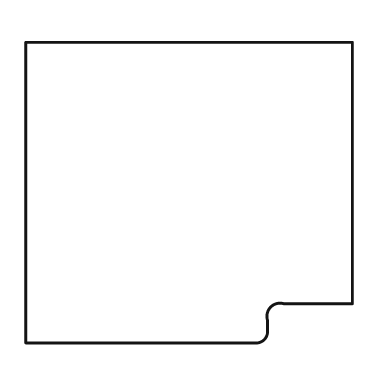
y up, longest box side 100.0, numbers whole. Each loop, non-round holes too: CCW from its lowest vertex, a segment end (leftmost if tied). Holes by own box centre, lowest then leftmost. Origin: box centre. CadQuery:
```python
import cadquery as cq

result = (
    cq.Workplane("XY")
    .moveTo(-50.0, -46.0)
    .lineTo(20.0, -46.0)
    .threePointArc((23.0, -45.0), (24.0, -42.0))
    .lineTo(24.0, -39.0)
    .threePointArc((25.0, -35.0), (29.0, -34.0))
    .lineTo(50.0, -34.0)
    .lineTo(50.0, 46.0)
    .lineTo(-50.0, 46.0)
    .close()
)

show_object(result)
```